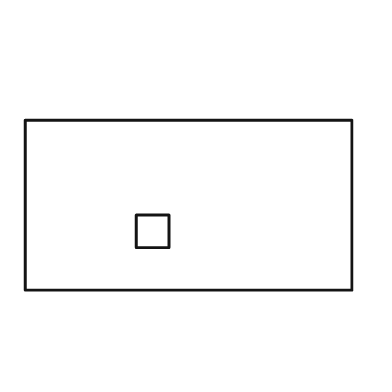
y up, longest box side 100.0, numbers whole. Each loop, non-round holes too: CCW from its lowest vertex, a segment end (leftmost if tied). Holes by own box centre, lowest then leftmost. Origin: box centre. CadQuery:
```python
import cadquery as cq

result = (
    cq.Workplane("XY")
    .moveTo(-50.0, -26.0)
    .lineTo(50.0, -26.0)
    .lineTo(50.0, 26.0)
    .lineTo(-50.0, 26.0)
    .close()
    .moveTo(-16.0, -13.0)
    .lineTo(-6.0, -13.0)
    .lineTo(-6.0, -3.0)
    .lineTo(-16.0, -3.0)
    .close()
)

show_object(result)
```